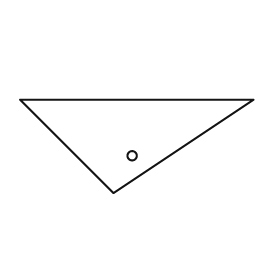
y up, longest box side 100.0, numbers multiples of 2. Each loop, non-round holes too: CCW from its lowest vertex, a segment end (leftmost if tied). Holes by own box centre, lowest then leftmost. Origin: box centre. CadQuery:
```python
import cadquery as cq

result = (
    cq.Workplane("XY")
    .moveTo(-10.0, -20.0)
    .lineTo(50.0, 20.0)
    .lineTo(-50.0, 20.0)
    .close()
    .moveTo(-2.0, -4.0)
    .circle(2.0)
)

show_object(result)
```